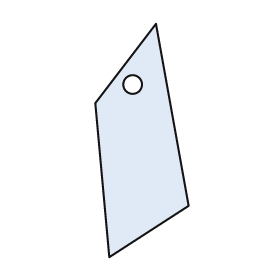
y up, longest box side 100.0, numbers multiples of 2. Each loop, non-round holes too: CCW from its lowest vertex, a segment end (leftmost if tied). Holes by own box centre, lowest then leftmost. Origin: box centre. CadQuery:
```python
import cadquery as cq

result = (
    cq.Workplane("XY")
    .moveTo(-14.0, -50.0)
    .lineTo(20.0, -28.0)
    .lineTo(6.0, 50.0)
    .lineTo(-20.0, 16.0)
    .close()
    .moveTo(-4.0, 24.0)
    .circle(4.0)
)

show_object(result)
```